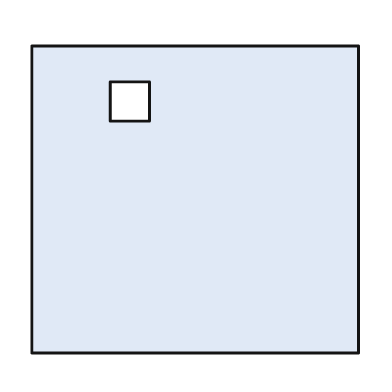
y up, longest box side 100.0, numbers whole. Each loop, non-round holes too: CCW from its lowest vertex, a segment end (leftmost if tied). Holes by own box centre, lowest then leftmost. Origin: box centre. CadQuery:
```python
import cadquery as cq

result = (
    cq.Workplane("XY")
    .moveTo(-50.0, -47.0)
    .lineTo(50.0, -47.0)
    .lineTo(50.0, 47.0)
    .lineTo(-50.0, 47.0)
    .close()
    .moveTo(-26.0, 24.0)
    .lineTo(-14.0, 24.0)
    .lineTo(-14.0, 36.0)
    .lineTo(-26.0, 36.0)
    .close()
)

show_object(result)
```